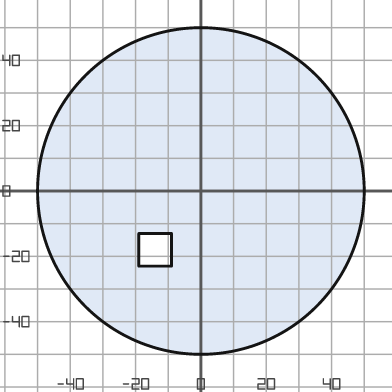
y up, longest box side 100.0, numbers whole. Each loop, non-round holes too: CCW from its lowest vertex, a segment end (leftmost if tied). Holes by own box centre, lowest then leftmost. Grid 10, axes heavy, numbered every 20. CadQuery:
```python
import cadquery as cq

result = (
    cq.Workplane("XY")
    .moveTo(0.0, 0.0)
    .circle(50.0)
    .moveTo(-19.0, -23.0)
    .lineTo(-9.0, -23.0)
    .lineTo(-9.0, -13.0)
    .lineTo(-19.0, -13.0)
    .close()
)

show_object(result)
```